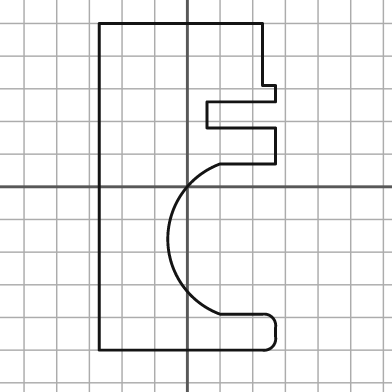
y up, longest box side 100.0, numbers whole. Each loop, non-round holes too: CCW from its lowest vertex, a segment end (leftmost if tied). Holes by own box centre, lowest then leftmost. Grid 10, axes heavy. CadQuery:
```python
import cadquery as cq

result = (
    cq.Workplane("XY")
    .moveTo(-27.0, -50.0)
    .lineTo(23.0, -50.0)
    .threePointArc((26.0, -49.0), (27.0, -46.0))
    .lineTo(27.0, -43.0)
    .threePointArc((26.0, -40.0), (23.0, -39.0))
    .lineTo(10.0, -39.0)
    .threePointArc((-6.0, -16.0), (10.0, 7.0))
    .lineTo(27.0, 7.0)
    .lineTo(27.0, 18.0)
    .lineTo(6.0, 18.0)
    .lineTo(6.0, 26.0)
    .lineTo(27.0, 26.0)
    .lineTo(27.0, 31.0)
    .lineTo(23.0, 31.0)
    .lineTo(23.0, 50.0)
    .lineTo(-27.0, 50.0)
    .close()
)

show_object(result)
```